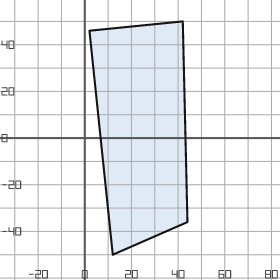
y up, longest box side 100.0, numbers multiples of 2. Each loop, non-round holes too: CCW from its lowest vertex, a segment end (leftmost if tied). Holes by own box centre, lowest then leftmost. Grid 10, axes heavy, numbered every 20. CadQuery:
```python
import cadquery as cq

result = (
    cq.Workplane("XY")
    .moveTo(12.0, -50.0)
    .lineTo(44.0, -36.0)
    .lineTo(42.0, 50.0)
    .lineTo(2.0, 46.0)
    .close()
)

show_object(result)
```